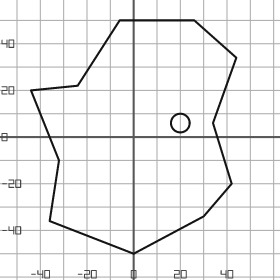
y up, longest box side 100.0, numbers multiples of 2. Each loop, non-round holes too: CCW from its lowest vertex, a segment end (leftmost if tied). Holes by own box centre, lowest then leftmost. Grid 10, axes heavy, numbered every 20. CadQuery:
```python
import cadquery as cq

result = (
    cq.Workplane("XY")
    .moveTo(0.0, -50.0)
    .lineTo(30.0, -34.0)
    .lineTo(42.0, -20.0)
    .lineTo(34.0, 6.0)
    .lineTo(44.0, 34.0)
    .lineTo(26.0, 50.0)
    .lineTo(-6.0, 50.0)
    .lineTo(-24.0, 22.0)
    .lineTo(-44.0, 20.0)
    .lineTo(-32.0, -10.0)
    .lineTo(-36.0, -36.0)
    .close()
    .moveTo(20.0, 6.0)
    .circle(4.0)
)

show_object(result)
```